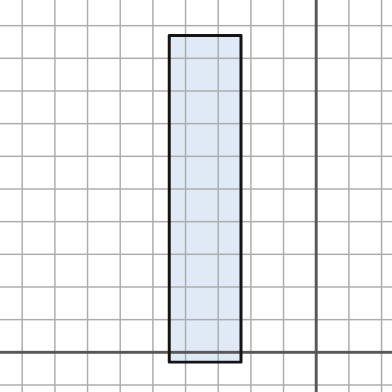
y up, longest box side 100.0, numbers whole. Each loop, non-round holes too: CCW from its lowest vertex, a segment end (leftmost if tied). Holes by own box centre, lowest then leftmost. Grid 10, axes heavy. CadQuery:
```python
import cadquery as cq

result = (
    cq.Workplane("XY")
    .moveTo(-45.0, -3.0)
    .lineTo(-23.0, -3.0)
    .lineTo(-23.0, 97.0)
    .lineTo(-45.0, 97.0)
    .close()
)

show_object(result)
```